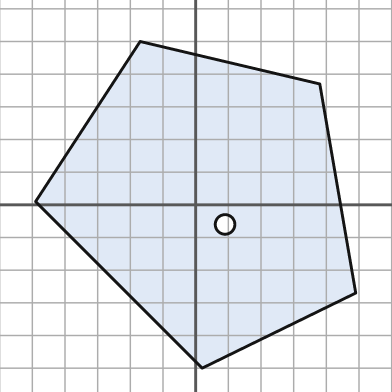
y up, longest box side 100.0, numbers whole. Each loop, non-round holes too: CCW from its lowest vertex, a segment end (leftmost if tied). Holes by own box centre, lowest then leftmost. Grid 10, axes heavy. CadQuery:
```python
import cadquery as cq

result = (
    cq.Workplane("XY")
    .moveTo(2.0, -50.0)
    .lineTo(49.0, -27.0)
    .lineTo(38.0, 37.0)
    .lineTo(-17.0, 50.0)
    .lineTo(-49.0, 1.0)
    .close()
    .moveTo(9.0, -6.0)
    .circle(3.0)
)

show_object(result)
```